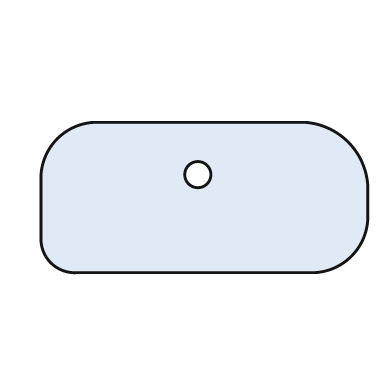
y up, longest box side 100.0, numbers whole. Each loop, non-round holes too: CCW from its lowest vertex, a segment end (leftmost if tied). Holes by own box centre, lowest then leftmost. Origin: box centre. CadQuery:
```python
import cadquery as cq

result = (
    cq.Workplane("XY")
    .moveTo(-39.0, -23.0)
    .lineTo(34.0, -23.0)
    .threePointArc((45.0, -18.0), (50.0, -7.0))
    .lineTo(50.0, 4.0)
    .threePointArc((44.0, 17.0), (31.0, 23.0))
    .lineTo(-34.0, 23.0)
    .threePointArc((-45.0, 18.0), (-50.0, 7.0))
    .lineTo(-50.0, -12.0)
    .threePointArc((-47.0, -20.0), (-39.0, -23.0))
    .close()
    .moveTo(-2.0, 7.0)
    .circle(4.0)
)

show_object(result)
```